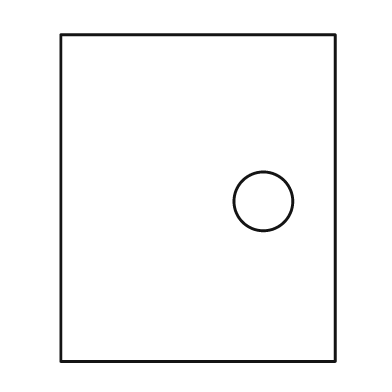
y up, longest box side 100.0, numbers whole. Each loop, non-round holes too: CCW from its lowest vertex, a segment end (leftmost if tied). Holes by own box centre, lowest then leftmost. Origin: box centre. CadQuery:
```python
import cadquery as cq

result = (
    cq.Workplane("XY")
    .moveTo(-42.0, -50.0)
    .lineTo(42.0, -50.0)
    .lineTo(42.0, 50.0)
    .lineTo(-42.0, 50.0)
    .close()
    .moveTo(20.0, -1.0)
    .circle(9.0)
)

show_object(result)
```